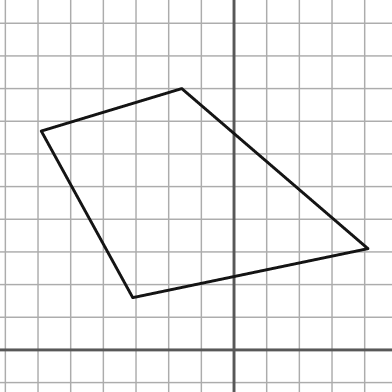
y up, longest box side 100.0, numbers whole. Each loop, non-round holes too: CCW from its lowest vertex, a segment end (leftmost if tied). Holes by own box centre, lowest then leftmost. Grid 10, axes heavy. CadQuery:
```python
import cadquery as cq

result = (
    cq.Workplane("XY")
    .moveTo(-31.0, 16.0)
    .lineTo(41.0, 31.0)
    .lineTo(-16.0, 80.0)
    .lineTo(-59.0, 67.0)
    .close()
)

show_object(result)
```